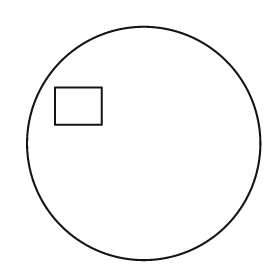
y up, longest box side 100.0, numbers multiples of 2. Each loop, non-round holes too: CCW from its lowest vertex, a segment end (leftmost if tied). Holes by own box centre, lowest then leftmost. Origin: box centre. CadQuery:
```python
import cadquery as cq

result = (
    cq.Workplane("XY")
    .moveTo(0.0, 0.0)
    .circle(50.0)
    .moveTo(-38.0, 8.0)
    .lineTo(-18.0, 8.0)
    .lineTo(-18.0, 24.0)
    .lineTo(-38.0, 24.0)
    .close()
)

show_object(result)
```